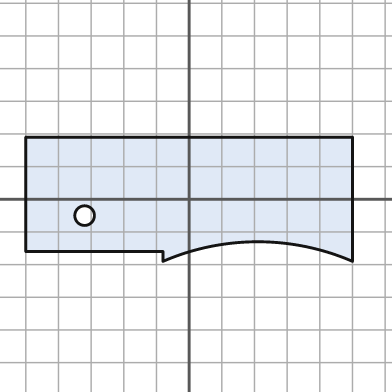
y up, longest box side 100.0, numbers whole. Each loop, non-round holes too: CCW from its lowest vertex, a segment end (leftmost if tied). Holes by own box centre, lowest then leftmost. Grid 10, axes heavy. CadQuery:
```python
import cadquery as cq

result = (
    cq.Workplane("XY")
    .moveTo(-8.0, -19.0)
    .threePointArc((21.0, -13.0), (50.0, -19.0))
    .lineTo(50.0, 19.0)
    .lineTo(-50.0, 19.0)
    .lineTo(-50.0, -16.0)
    .lineTo(-8.0, -16.0)
    .close()
    .moveTo(-32.0, -5.0)
    .circle(3.0)
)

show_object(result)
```